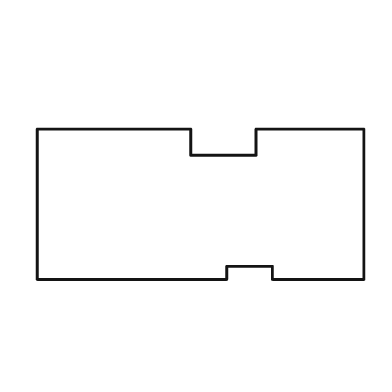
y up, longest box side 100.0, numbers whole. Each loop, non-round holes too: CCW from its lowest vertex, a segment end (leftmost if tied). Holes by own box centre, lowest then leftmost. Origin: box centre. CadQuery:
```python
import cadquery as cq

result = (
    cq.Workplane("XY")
    .moveTo(-50.0, -23.0)
    .lineTo(8.0, -23.0)
    .lineTo(8.0, -19.0)
    .lineTo(22.0, -19.0)
    .lineTo(22.0, -23.0)
    .lineTo(50.0, -23.0)
    .lineTo(50.0, 23.0)
    .lineTo(17.0, 23.0)
    .lineTo(17.0, 15.0)
    .lineTo(-3.0, 15.0)
    .lineTo(-3.0, 23.0)
    .lineTo(-50.0, 23.0)
    .close()
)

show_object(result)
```